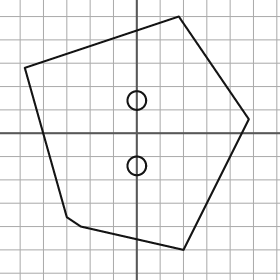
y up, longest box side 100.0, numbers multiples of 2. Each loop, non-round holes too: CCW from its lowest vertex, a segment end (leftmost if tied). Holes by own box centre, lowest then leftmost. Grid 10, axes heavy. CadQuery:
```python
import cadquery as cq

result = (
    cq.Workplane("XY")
    .moveTo(20.0, -50.0)
    .lineTo(48.0, 6.0)
    .lineTo(18.0, 50.0)
    .lineTo(-48.0, 28.0)
    .lineTo(-30.0, -36.0)
    .lineTo(-24.0, -40.0)
    .close()
    .moveTo(0.0, -14.0)
    .circle(4.0)
    .moveTo(0.0, 14.0)
    .circle(4.0)
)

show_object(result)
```